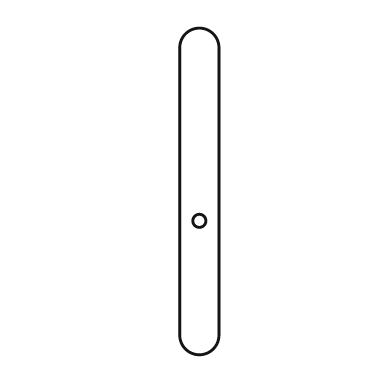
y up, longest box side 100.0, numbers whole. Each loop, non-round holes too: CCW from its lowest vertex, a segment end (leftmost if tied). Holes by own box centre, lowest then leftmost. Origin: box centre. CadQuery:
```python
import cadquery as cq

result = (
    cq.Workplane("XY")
    .moveTo(-6.0, -44.0)
    .threePointArc((0.0, -50.0), (6.0, -44.0))
    .lineTo(6.0, 44.0)
    .threePointArc((0.0, 50.0), (-6.0, 44.0))
    .close()
    .moveTo(0.0, -9.0)
    .circle(2.0)
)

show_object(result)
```